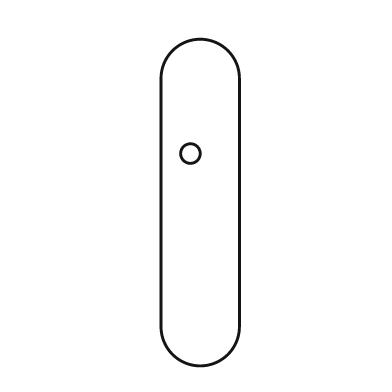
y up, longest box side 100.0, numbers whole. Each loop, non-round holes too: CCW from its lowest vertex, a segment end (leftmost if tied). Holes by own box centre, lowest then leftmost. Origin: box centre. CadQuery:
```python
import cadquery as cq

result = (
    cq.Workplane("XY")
    .moveTo(-12.0, -38.0)
    .threePointArc((0.0, -50.0), (12.0, -38.0))
    .lineTo(12.0, 38.0)
    .threePointArc((0.0, 50.0), (-12.0, 38.0))
    .close()
    .moveTo(-3.0, 15.0)
    .circle(3.0)
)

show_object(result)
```